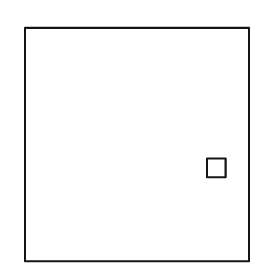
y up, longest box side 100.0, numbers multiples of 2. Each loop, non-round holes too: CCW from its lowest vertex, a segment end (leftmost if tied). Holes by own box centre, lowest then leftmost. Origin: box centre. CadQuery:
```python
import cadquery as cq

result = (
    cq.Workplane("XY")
    .moveTo(-48.0, -50.0)
    .lineTo(48.0, -50.0)
    .lineTo(48.0, 50.0)
    .lineTo(-48.0, 50.0)
    .close()
    .moveTo(30.0, -14.0)
    .lineTo(38.0, -14.0)
    .lineTo(38.0, -6.0)
    .lineTo(30.0, -6.0)
    .close()
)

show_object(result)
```